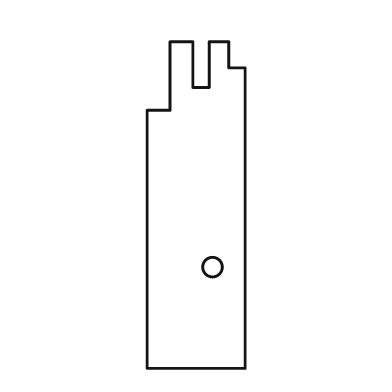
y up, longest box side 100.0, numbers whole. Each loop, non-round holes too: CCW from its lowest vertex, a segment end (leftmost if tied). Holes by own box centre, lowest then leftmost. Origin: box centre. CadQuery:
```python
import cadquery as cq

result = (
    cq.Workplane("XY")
    .moveTo(-15.0, -50.0)
    .lineTo(15.0, -50.0)
    .lineTo(15.0, 42.0)
    .lineTo(10.0, 42.0)
    .lineTo(10.0, 50.0)
    .lineTo(4.0, 50.0)
    .lineTo(4.0, 36.0)
    .lineTo(-1.0, 36.0)
    .lineTo(-1.0, 50.0)
    .lineTo(-8.0, 50.0)
    .lineTo(-8.0, 29.0)
    .lineTo(-15.0, 29.0)
    .close()
    .moveTo(5.0, -19.0)
    .circle(3.0)
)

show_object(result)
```